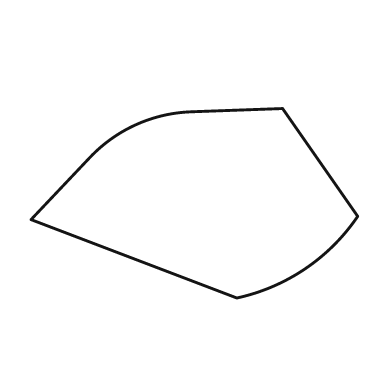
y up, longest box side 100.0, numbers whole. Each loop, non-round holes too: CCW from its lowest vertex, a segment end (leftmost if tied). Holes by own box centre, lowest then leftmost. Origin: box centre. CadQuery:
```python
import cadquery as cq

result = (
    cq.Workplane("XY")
    .moveTo(13.0, -29.0)
    .threePointArc((34.0, -20.0), (50.0, -4.0))
    .lineTo(27.0, 29.0)
    .lineTo(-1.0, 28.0)
    .threePointArc((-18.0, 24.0), (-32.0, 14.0))
    .lineTo(-50.0, -5.0)
    .close()
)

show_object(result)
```